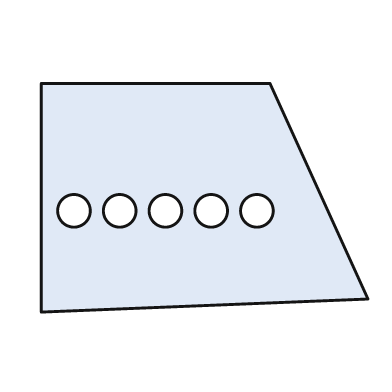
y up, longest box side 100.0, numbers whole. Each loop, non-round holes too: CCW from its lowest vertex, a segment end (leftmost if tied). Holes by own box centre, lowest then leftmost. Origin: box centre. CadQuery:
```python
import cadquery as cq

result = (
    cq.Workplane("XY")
    .moveTo(-50.0, -35.0)
    .lineTo(50.0, -31.0)
    .lineTo(20.0, 35.0)
    .lineTo(-50.0, 35.0)
    .close()
    .moveTo(-40.0, -4.0)
    .circle(5.0)
    .moveTo(-26.0, -4.0)
    .circle(5.0)
    .moveTo(-12.0, -4.0)
    .circle(5.0)
    .moveTo(2.0, -4.0)
    .circle(5.0)
    .moveTo(16.0, -4.0)
    .circle(5.0)
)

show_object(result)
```